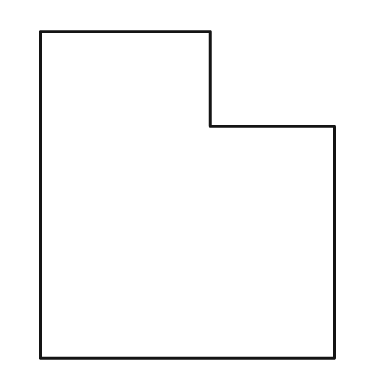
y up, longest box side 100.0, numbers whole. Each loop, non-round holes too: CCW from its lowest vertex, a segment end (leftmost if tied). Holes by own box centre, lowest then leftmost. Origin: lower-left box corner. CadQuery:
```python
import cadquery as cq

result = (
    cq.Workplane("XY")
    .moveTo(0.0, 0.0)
    .lineTo(90.0, 0.0)
    .lineTo(90.0, 71.0)
    .lineTo(52.0, 71.0)
    .lineTo(52.0, 100.0)
    .lineTo(0.0, 100.0)
    .close()
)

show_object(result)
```